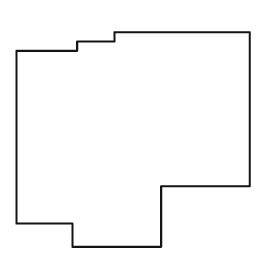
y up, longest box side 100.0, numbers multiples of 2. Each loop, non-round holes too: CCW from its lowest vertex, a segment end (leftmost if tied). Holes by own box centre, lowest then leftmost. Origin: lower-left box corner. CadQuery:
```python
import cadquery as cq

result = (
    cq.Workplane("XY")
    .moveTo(24.0, 0.0)
    .lineTo(62.0, 0.0)
    .lineTo(62.0, 26.0)
    .lineTo(100.0, 26.0)
    .lineTo(100.0, 92.0)
    .lineTo(42.0, 92.0)
    .lineTo(42.0, 88.0)
    .lineTo(26.0, 88.0)
    .lineTo(26.0, 84.0)
    .lineTo(0.0, 84.0)
    .lineTo(0.0, 10.0)
    .lineTo(24.0, 10.0)
    .close()
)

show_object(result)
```